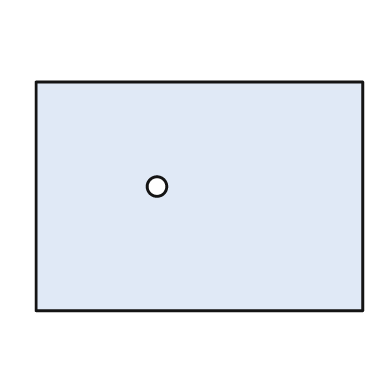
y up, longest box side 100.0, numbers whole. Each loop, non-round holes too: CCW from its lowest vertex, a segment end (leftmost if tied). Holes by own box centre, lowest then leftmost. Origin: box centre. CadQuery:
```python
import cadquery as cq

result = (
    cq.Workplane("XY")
    .moveTo(-50.0, -35.0)
    .lineTo(50.0, -35.0)
    .lineTo(50.0, 35.0)
    .lineTo(-50.0, 35.0)
    .close()
    .moveTo(-13.0, 3.0)
    .circle(3.0)
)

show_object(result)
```